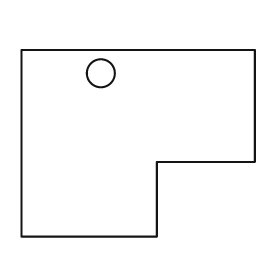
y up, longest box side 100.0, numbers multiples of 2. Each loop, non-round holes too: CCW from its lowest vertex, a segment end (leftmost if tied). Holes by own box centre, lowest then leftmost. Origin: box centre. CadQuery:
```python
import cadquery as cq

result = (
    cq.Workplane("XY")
    .moveTo(-50.0, -40.0)
    .lineTo(8.0, -40.0)
    .lineTo(8.0, -8.0)
    .lineTo(50.0, -8.0)
    .lineTo(50.0, 40.0)
    .lineTo(-50.0, 40.0)
    .close()
    .moveTo(-16.0, 30.0)
    .circle(6.0)
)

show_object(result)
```